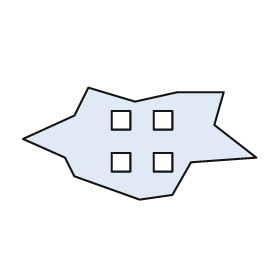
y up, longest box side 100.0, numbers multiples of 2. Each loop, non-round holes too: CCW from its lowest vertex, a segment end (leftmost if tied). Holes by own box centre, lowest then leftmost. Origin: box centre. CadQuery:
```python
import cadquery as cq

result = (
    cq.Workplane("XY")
    .moveTo(0.0, -24.0)
    .lineTo(14.0, -22.0)
    .lineTo(22.0, -8.0)
    .lineTo(50.0, -6.0)
    .lineTo(32.0, 8.0)
    .lineTo(36.0, 22.0)
    .lineTo(16.0, 22.0)
    .lineTo(-2.0, 18.0)
    .lineTo(-22.0, 24.0)
    .lineTo(-28.0, 12.0)
    .lineTo(-50.0, 2.0)
    .lineTo(-32.0, -6.0)
    .lineTo(-28.0, -14.0)
    .close()
    .moveTo(-12.0, -12.0)
    .lineTo(-4.0, -12.0)
    .lineTo(-4.0, -4.0)
    .lineTo(-12.0, -4.0)
    .close()
    .moveTo(6.0, -12.0)
    .lineTo(14.0, -12.0)
    .lineTo(14.0, -4.0)
    .lineTo(6.0, -4.0)
    .close()
    .moveTo(-12.0, 6.0)
    .lineTo(-4.0, 6.0)
    .lineTo(-4.0, 14.0)
    .lineTo(-12.0, 14.0)
    .close()
    .moveTo(6.0, 6.0)
    .lineTo(14.0, 6.0)
    .lineTo(14.0, 14.0)
    .lineTo(6.0, 14.0)
    .close()
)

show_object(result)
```